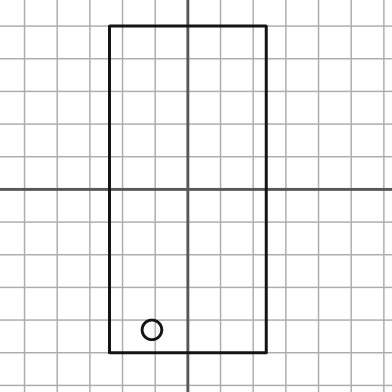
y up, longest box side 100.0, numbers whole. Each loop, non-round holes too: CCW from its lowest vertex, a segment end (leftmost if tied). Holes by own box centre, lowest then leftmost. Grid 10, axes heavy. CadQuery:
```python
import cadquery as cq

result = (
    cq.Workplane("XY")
    .moveTo(-24.0, -50.0)
    .lineTo(24.0, -50.0)
    .lineTo(24.0, 50.0)
    .lineTo(-24.0, 50.0)
    .close()
    .moveTo(-11.0, -43.0)
    .circle(3.0)
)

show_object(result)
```